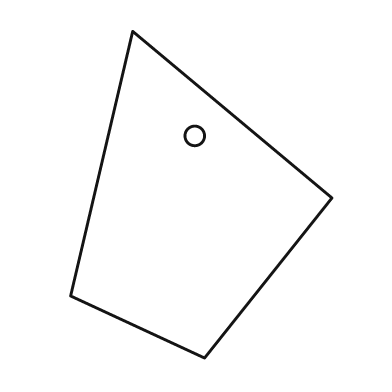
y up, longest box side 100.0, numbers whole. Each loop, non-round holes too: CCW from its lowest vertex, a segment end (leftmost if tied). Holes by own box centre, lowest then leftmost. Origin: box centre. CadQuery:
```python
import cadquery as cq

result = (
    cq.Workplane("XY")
    .moveTo(1.0, -50.0)
    .lineTo(40.0, -1.0)
    .lineTo(-21.0, 50.0)
    .lineTo(-40.0, -31.0)
    .close()
    .moveTo(-2.0, 18.0)
    .circle(3.0)
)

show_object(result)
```